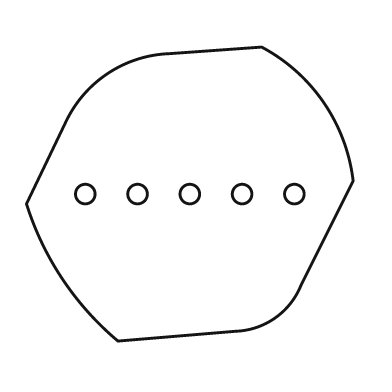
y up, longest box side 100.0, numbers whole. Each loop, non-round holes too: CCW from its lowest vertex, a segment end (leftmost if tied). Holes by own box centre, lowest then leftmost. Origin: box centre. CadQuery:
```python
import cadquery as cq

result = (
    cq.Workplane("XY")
    .moveTo(-22.0, -45.0)
    .lineTo(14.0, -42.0)
    .threePointArc((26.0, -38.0), (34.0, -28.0))
    .lineTo(50.0, 4.0)
    .threePointArc((41.0, 28.0), (22.0, 45.0))
    .lineTo(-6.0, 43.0)
    .threePointArc((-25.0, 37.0), (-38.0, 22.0))
    .lineTo(-50.0, -3.0)
    .threePointArc((-39.0, -26.0), (-22.0, -45.0))
    .close()
    .moveTo(-32.0, 0.0)
    .circle(3.0)
    .moveTo(-16.0, 0.0)
    .circle(3.0)
    .moveTo(0.0, 0.0)
    .circle(3.0)
    .moveTo(16.0, 0.0)
    .circle(3.0)
    .moveTo(32.0, 0.0)
    .circle(3.0)
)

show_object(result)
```